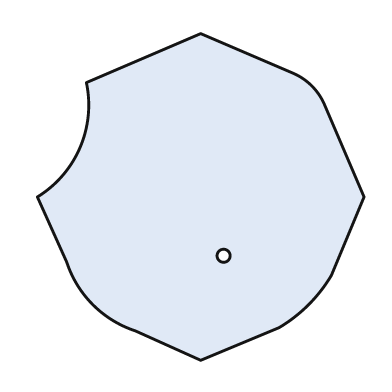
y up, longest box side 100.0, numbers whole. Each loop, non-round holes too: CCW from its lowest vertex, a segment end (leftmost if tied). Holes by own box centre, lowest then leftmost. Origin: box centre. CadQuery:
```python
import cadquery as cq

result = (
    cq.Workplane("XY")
    .moveTo(0.0, -50.0)
    .lineTo(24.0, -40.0)
    .threePointArc((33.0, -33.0), (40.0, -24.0))
    .lineTo(50.0, 0.0)
    .lineTo(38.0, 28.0)
    .threePointArc((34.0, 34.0), (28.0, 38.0))
    .lineTo(0.0, 50.0)
    .lineTo(-35.0, 35.0)
    .threePointArc((-37.0, 15.0), (-50.0, 0.0))
    .lineTo(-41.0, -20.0)
    .threePointArc((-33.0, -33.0), (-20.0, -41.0))
    .close()
    .moveTo(7.0, -18.0)
    .circle(2.0)
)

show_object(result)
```